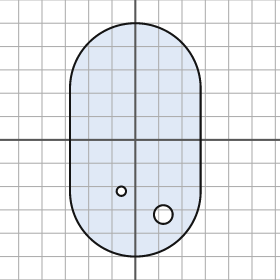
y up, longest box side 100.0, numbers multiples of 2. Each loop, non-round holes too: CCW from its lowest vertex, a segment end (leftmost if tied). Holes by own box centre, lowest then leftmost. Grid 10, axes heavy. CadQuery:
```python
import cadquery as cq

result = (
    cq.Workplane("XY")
    .moveTo(-28.0, -22.0)
    .threePointArc((0.0, -50.0), (28.0, -22.0))
    .lineTo(28.0, 22.0)
    .threePointArc((0.0, 50.0), (-28.0, 22.0))
    .close()
    .moveTo(12.0, -32.0)
    .circle(4.0)
    .moveTo(-6.0, -22.0)
    .circle(2.0)
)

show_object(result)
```